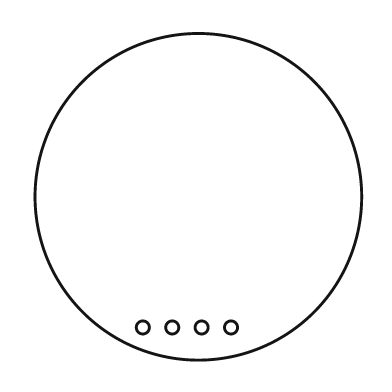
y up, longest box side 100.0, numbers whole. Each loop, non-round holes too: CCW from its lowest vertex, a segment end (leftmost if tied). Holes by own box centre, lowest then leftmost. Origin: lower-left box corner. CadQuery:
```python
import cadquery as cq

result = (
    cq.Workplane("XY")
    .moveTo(50.0, 50.0)
    .circle(50.0)
    .moveTo(33.0, 10.0)
    .circle(2.0)
    .moveTo(42.0, 10.0)
    .circle(2.0)
    .moveTo(51.0, 10.0)
    .circle(2.0)
    .moveTo(60.0, 10.0)
    .circle(2.0)
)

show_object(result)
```